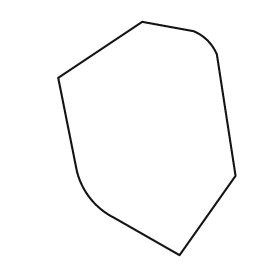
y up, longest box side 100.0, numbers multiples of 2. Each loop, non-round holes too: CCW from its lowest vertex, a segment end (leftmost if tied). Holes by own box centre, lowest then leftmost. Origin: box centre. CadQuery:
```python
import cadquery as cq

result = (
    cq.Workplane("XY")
    .moveTo(14.0, -50.0)
    .lineTo(38.0, -16.0)
    .lineTo(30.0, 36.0)
    .threePointArc((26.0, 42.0), (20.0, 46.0))
    .lineTo(-2.0, 50.0)
    .lineTo(-38.0, 26.0)
    .lineTo(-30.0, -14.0)
    .threePointArc((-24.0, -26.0), (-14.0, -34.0))
    .close()
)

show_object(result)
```